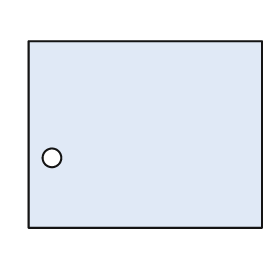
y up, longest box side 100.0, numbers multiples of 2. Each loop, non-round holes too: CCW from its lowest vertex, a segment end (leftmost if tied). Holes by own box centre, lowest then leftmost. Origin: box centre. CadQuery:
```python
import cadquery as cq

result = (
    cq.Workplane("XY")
    .moveTo(-50.0, -40.0)
    .lineTo(50.0, -40.0)
    .lineTo(50.0, 40.0)
    .lineTo(-50.0, 40.0)
    .close()
    .moveTo(-40.0, -10.0)
    .circle(4.0)
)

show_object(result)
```